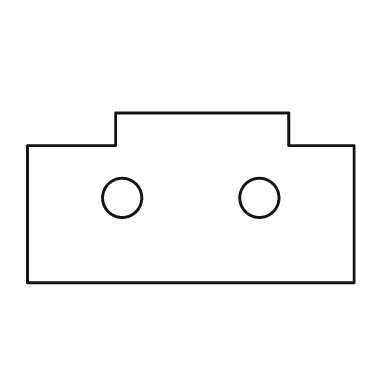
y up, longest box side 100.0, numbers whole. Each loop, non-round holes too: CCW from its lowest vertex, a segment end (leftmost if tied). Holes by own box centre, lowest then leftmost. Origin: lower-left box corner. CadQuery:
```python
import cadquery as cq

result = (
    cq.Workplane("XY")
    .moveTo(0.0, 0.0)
    .lineTo(100.0, 0.0)
    .lineTo(100.0, 42.0)
    .lineTo(80.0, 42.0)
    .lineTo(80.0, 52.0)
    .lineTo(27.0, 52.0)
    .lineTo(27.0, 42.0)
    .lineTo(0.0, 42.0)
    .close()
    .moveTo(29.0, 26.0)
    .circle(6.0)
    .moveTo(71.0, 26.0)
    .circle(6.0)
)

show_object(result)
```